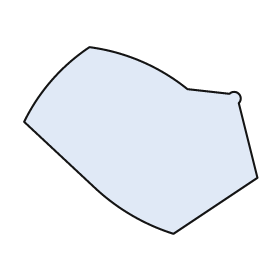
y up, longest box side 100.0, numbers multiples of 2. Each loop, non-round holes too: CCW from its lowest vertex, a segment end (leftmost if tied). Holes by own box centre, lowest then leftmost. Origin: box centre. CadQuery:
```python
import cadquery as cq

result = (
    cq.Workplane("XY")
    .moveTo(14.0, -40.0)
    .lineTo(50.0, -16.0)
    .lineTo(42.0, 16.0)
    .threePointArc((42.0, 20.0), (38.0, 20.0))
    .lineTo(20.0, 22.0)
    .threePointArc((0.0, 34.0), (-22.0, 40.0))
    .threePointArc((-38.0, 26.0), (-50.0, 8.0))
    .lineTo(-20.0, -20.0)
    .threePointArc((-4.0, -32.0), (14.0, -40.0))
    .close()
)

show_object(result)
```